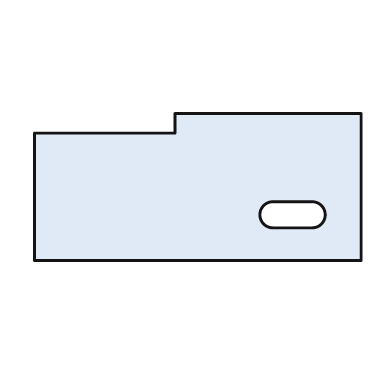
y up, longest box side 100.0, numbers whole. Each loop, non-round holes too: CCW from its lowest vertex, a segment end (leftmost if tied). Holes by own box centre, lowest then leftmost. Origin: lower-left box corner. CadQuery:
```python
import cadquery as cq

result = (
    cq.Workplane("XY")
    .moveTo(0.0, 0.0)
    .lineTo(100.0, 0.0)
    .lineTo(100.0, 45.0)
    .lineTo(43.0, 45.0)
    .lineTo(43.0, 39.0)
    .lineTo(0.0, 39.0)
    .close()
    .moveTo(73.0, 10.0)
    .lineTo(85.0, 10.0)
    .threePointArc((89.0, 14.0), (85.0, 18.0))
    .lineTo(73.0, 18.0)
    .threePointArc((69.0, 14.0), (73.0, 10.0))
    .close()
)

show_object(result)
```